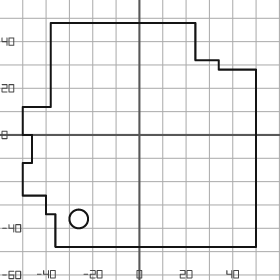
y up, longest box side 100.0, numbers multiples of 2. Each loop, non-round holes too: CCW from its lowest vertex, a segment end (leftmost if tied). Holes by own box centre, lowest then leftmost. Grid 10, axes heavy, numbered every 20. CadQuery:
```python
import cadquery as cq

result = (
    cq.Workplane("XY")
    .moveTo(-36.0, -48.0)
    .lineTo(50.0, -48.0)
    .lineTo(50.0, 28.0)
    .lineTo(34.0, 28.0)
    .lineTo(34.0, 32.0)
    .lineTo(24.0, 32.0)
    .lineTo(24.0, 48.0)
    .lineTo(-38.0, 48.0)
    .lineTo(-38.0, 12.0)
    .lineTo(-50.0, 12.0)
    .lineTo(-50.0, 0.0)
    .lineTo(-46.0, 0.0)
    .lineTo(-46.0, -12.0)
    .lineTo(-50.0, -12.0)
    .lineTo(-50.0, -26.0)
    .lineTo(-40.0, -26.0)
    .lineTo(-40.0, -34.0)
    .lineTo(-36.0, -34.0)
    .close()
    .moveTo(-26.0, -36.0)
    .circle(4.0)
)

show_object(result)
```